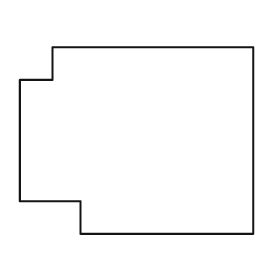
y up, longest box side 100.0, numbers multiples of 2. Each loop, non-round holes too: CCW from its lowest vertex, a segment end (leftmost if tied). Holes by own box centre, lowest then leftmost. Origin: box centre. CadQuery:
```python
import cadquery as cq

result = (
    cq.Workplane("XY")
    .moveTo(-24.0, -40.0)
    .lineTo(50.0, -40.0)
    .lineTo(50.0, 40.0)
    .lineTo(-36.0, 40.0)
    .lineTo(-36.0, 26.0)
    .lineTo(-50.0, 26.0)
    .lineTo(-50.0, -26.0)
    .lineTo(-24.0, -26.0)
    .close()
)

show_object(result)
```